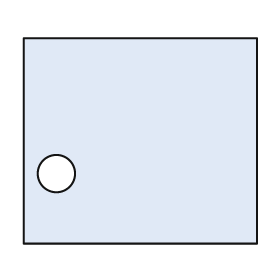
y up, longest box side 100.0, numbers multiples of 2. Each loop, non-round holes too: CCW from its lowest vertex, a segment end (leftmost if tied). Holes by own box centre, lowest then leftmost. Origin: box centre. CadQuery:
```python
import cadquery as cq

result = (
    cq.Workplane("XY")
    .moveTo(-50.0, -44.0)
    .lineTo(50.0, -44.0)
    .lineTo(50.0, 44.0)
    .lineTo(-50.0, 44.0)
    .close()
    .moveTo(-36.0, -14.0)
    .circle(8.0)
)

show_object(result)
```